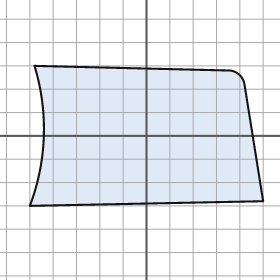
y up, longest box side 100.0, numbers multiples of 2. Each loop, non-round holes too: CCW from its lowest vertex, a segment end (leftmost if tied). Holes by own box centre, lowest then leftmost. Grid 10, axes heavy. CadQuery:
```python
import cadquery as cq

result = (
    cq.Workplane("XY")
    .moveTo(-50.0, -30.0)
    .lineTo(50.0, -28.0)
    .lineTo(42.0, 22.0)
    .threePointArc((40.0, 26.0), (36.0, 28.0))
    .lineTo(-48.0, 30.0)
    .threePointArc((-44.0, 0.0), (-50.0, -30.0))
    .close()
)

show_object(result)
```